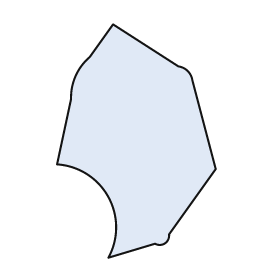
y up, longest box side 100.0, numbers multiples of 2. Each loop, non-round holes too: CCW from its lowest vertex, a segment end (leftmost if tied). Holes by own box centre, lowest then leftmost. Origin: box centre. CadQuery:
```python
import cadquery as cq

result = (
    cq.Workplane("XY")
    .moveTo(-12.0, -50.0)
    .lineTo(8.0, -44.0)
    .threePointArc((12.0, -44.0), (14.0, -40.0))
    .lineTo(34.0, -12.0)
    .lineTo(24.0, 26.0)
    .threePointArc((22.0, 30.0), (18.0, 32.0))
    .lineTo(-10.0, 50.0)
    .lineTo(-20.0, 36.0)
    .threePointArc((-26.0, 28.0), (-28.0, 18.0))
    .lineTo(-34.0, -10.0)
    .threePointArc((-12.0, -24.0), (-12.0, -50.0))
    .close()
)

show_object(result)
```